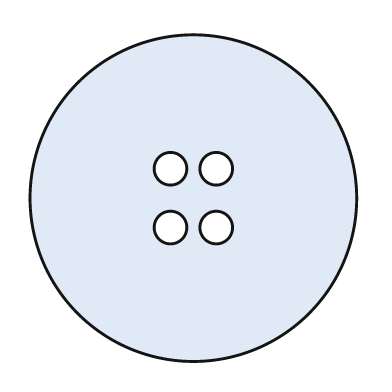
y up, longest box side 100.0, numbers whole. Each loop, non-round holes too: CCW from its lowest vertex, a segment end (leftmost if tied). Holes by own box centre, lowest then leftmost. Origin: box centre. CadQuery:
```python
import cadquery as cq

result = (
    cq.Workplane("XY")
    .moveTo(0.0, 0.0)
    .circle(50.0)
    .moveTo(-7.0, -9.0)
    .circle(5.0)
    .moveTo(7.0, -9.0)
    .circle(5.0)
    .moveTo(-7.0, 9.0)
    .circle(5.0)
    .moveTo(7.0, 9.0)
    .circle(5.0)
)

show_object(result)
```